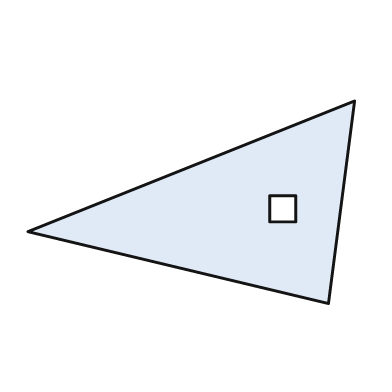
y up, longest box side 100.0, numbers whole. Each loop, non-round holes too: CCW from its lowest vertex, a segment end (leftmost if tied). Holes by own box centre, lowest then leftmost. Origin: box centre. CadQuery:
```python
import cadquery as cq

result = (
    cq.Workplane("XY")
    .moveTo(42.0, -31.0)
    .lineTo(50.0, 31.0)
    .lineTo(-50.0, -9.0)
    .close()
    .moveTo(24.0, -6.0)
    .lineTo(32.0, -6.0)
    .lineTo(32.0, 2.0)
    .lineTo(24.0, 2.0)
    .close()
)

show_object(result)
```